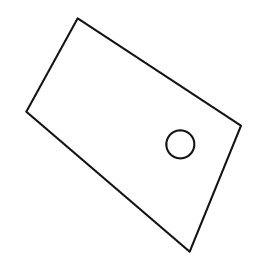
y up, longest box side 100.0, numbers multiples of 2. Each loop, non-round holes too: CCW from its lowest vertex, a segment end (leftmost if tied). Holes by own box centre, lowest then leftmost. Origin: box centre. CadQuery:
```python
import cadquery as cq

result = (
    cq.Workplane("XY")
    .moveTo(24.0, -50.0)
    .lineTo(46.0, 4.0)
    .lineTo(-24.0, 50.0)
    .lineTo(-46.0, 10.0)
    .close()
    .moveTo(20.0, -4.0)
    .circle(6.0)
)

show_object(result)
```